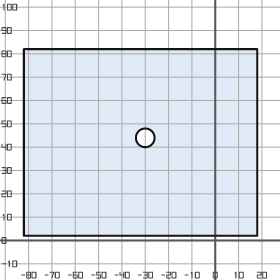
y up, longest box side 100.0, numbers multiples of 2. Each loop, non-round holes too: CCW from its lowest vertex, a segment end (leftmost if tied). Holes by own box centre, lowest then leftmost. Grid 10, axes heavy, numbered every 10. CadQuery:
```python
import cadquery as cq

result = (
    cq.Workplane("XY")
    .moveTo(-82.0, 2.0)
    .lineTo(18.0, 2.0)
    .lineTo(18.0, 82.0)
    .lineTo(-82.0, 82.0)
    .close()
    .moveTo(-30.0, 44.0)
    .circle(4.0)
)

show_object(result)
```